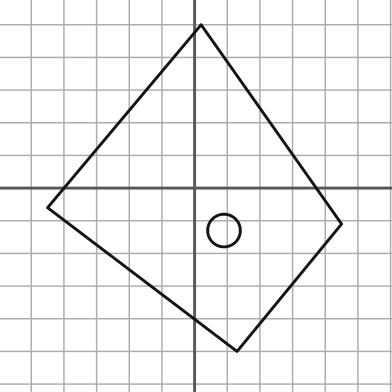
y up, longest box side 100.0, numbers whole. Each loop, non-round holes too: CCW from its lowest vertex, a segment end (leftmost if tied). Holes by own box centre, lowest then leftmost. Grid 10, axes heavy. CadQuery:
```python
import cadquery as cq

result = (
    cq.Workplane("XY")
    .moveTo(13.0, -50.0)
    .lineTo(45.0, -11.0)
    .lineTo(2.0, 50.0)
    .lineTo(-45.0, -6.0)
    .close()
    .moveTo(9.0, -13.0)
    .circle(5.0)
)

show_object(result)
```